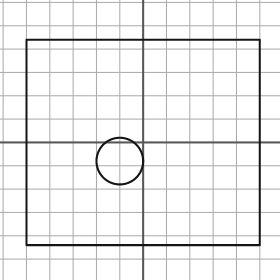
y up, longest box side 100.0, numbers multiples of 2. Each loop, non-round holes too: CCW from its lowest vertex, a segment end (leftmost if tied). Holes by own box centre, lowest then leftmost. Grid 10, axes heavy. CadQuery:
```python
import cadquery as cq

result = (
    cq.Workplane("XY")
    .moveTo(-50.0, -44.0)
    .lineTo(50.0, -44.0)
    .lineTo(50.0, 44.0)
    .lineTo(-50.0, 44.0)
    .close()
    .moveTo(-10.0, -8.0)
    .circle(10.0)
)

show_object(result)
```